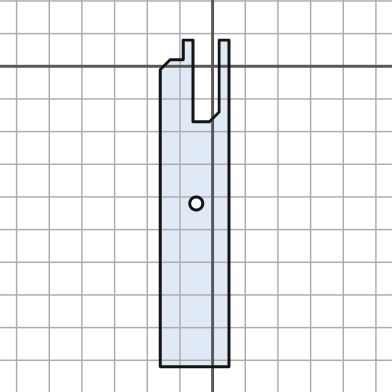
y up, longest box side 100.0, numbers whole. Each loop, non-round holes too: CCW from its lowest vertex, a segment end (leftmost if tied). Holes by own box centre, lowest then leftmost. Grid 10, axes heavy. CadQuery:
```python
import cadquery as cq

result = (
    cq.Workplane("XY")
    .moveTo(-16.0, -92.0)
    .lineTo(5.0, -92.0)
    .lineTo(5.0, 8.0)
    .lineTo(2.0, 8.0)
    .lineTo(2.0, -14.0)
    .lineTo(-1.0, -17.0)
    .lineTo(-6.0, -17.0)
    .lineTo(-6.0, 8.0)
    .lineTo(-9.0, 8.0)
    .lineTo(-9.0, 2.0)
    .lineTo(-13.0, 2.0)
    .lineTo(-16.0, -1.0)
    .close()
    .moveTo(-5.0, -42.0)
    .circle(2.0)
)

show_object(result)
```